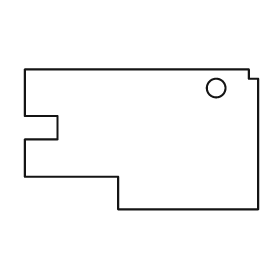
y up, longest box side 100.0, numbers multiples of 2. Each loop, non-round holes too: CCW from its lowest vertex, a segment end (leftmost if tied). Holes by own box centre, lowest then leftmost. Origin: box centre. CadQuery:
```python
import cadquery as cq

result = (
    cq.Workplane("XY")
    .moveTo(-10.0, -30.0)
    .lineTo(50.0, -30.0)
    .lineTo(50.0, 26.0)
    .lineTo(46.0, 26.0)
    .lineTo(46.0, 30.0)
    .lineTo(-50.0, 30.0)
    .lineTo(-50.0, 10.0)
    .lineTo(-36.0, 10.0)
    .lineTo(-36.0, 0.0)
    .lineTo(-50.0, 0.0)
    .lineTo(-50.0, -16.0)
    .lineTo(-10.0, -16.0)
    .close()
    .moveTo(32.0, 22.0)
    .circle(4.0)
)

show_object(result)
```